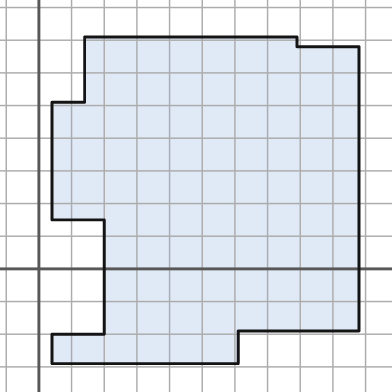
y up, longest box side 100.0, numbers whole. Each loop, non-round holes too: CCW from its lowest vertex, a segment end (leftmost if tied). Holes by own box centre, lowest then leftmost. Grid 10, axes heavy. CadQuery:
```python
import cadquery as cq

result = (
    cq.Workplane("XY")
    .moveTo(4.0, -29.0)
    .lineTo(61.0, -29.0)
    .lineTo(61.0, -19.0)
    .lineTo(98.0, -19.0)
    .lineTo(98.0, 68.0)
    .lineTo(79.0, 68.0)
    .lineTo(79.0, 71.0)
    .lineTo(14.0, 71.0)
    .lineTo(14.0, 51.0)
    .lineTo(4.0, 51.0)
    .lineTo(4.0, 15.0)
    .lineTo(20.0, 15.0)
    .lineTo(20.0, -20.0)
    .lineTo(4.0, -20.0)
    .close()
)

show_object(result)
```